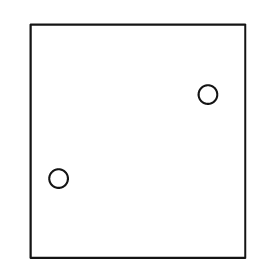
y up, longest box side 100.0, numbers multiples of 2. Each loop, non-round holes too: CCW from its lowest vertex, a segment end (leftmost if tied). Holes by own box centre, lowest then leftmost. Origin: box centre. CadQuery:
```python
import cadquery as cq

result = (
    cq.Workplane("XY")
    .moveTo(-46.0, -50.0)
    .lineTo(46.0, -50.0)
    .lineTo(46.0, 50.0)
    .lineTo(-46.0, 50.0)
    .close()
    .moveTo(-34.0, -16.0)
    .circle(4.0)
    .moveTo(30.0, 20.0)
    .circle(4.0)
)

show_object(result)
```